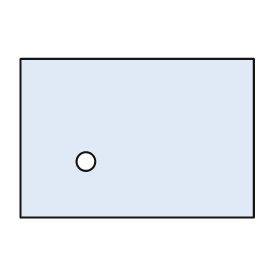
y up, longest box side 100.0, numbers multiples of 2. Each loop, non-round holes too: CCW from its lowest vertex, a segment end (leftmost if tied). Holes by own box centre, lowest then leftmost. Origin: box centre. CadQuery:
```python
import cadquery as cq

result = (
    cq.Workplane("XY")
    .moveTo(-50.0, -34.0)
    .lineTo(50.0, -34.0)
    .lineTo(50.0, 34.0)
    .lineTo(-50.0, 34.0)
    .close()
    .moveTo(-22.0, -10.0)
    .circle(4.0)
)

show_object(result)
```